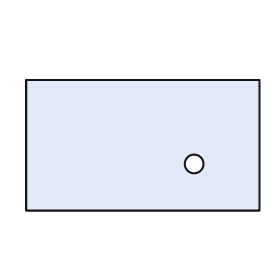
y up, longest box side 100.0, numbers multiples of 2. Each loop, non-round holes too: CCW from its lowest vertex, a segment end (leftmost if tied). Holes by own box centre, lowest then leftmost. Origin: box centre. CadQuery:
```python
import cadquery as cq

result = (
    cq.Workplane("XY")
    .moveTo(-50.0, -28.0)
    .lineTo(50.0, -28.0)
    .lineTo(50.0, 28.0)
    .lineTo(-50.0, 28.0)
    .close()
    .moveTo(22.0, -8.0)
    .circle(4.0)
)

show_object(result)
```